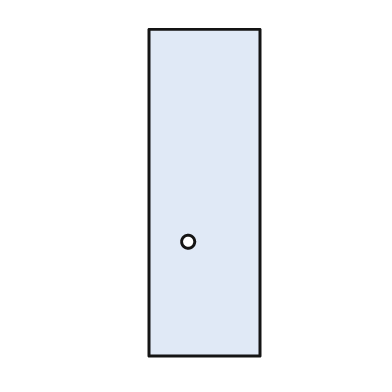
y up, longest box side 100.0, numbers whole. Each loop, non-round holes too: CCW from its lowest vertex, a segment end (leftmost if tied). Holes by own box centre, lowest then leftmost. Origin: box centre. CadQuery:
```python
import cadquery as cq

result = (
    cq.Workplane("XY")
    .moveTo(-17.0, -50.0)
    .lineTo(17.0, -50.0)
    .lineTo(17.0, 50.0)
    .lineTo(-17.0, 50.0)
    .close()
    .moveTo(-5.0, -15.0)
    .circle(2.0)
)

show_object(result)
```